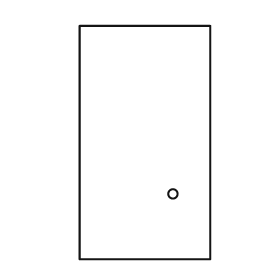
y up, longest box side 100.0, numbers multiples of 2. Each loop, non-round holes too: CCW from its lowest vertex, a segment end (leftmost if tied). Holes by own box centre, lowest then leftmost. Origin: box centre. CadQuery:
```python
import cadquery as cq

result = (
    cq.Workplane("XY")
    .moveTo(-28.0, -50.0)
    .lineTo(28.0, -50.0)
    .lineTo(28.0, 50.0)
    .lineTo(-28.0, 50.0)
    .close()
    .moveTo(12.0, -22.0)
    .circle(2.0)
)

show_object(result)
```